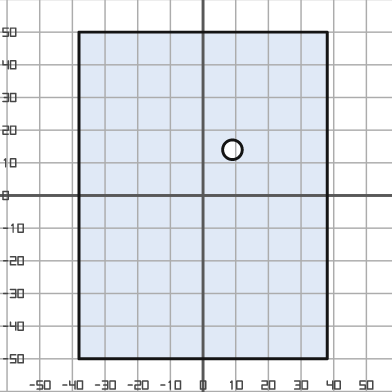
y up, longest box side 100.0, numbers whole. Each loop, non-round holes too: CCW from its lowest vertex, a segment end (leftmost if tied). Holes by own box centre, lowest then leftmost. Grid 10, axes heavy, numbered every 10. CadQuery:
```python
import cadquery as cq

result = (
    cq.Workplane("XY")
    .moveTo(-38.0, -50.0)
    .lineTo(38.0, -50.0)
    .lineTo(38.0, 50.0)
    .lineTo(-38.0, 50.0)
    .close()
    .moveTo(9.0, 14.0)
    .circle(3.0)
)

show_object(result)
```